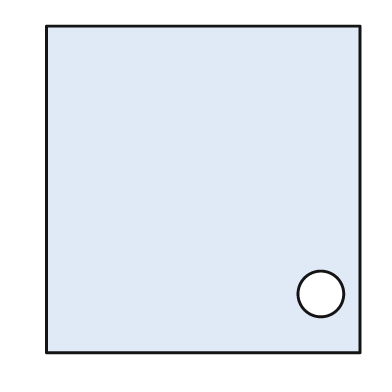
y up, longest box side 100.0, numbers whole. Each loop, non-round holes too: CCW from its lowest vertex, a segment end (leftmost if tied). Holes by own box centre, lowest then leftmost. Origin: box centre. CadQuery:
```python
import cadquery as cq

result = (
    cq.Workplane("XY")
    .moveTo(-48.0, -50.0)
    .lineTo(48.0, -50.0)
    .lineTo(48.0, 50.0)
    .lineTo(-48.0, 50.0)
    .close()
    .moveTo(36.0, -32.0)
    .circle(7.0)
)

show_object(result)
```